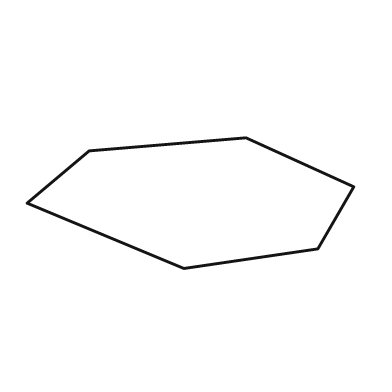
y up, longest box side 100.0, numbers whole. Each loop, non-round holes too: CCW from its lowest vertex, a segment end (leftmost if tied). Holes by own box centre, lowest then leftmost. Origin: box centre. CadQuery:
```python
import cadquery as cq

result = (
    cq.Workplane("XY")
    .moveTo(-2.0, -20.0)
    .lineTo(39.0, -14.0)
    .lineTo(50.0, 5.0)
    .lineTo(17.0, 20.0)
    .lineTo(-31.0, 16.0)
    .lineTo(-50.0, 0.0)
    .close()
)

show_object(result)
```